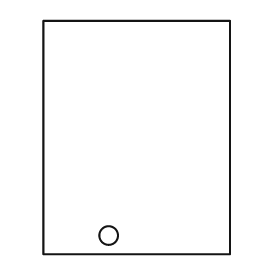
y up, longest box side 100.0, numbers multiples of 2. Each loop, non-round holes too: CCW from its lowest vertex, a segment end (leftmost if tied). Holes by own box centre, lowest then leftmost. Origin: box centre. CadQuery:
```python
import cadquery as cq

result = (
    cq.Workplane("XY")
    .moveTo(-40.0, -50.0)
    .lineTo(40.0, -50.0)
    .lineTo(40.0, 50.0)
    .lineTo(-40.0, 50.0)
    .close()
    .moveTo(-12.0, -42.0)
    .circle(4.0)
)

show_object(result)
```